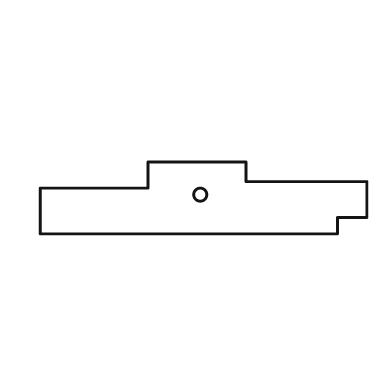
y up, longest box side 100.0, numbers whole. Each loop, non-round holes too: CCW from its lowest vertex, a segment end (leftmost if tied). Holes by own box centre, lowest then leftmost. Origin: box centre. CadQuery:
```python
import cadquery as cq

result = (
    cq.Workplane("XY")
    .moveTo(-50.0, -11.0)
    .lineTo(41.0, -11.0)
    .lineTo(41.0, -6.0)
    .lineTo(50.0, -6.0)
    .lineTo(50.0, 5.0)
    .lineTo(13.0, 5.0)
    .lineTo(13.0, 11.0)
    .lineTo(-17.0, 11.0)
    .lineTo(-17.0, 3.0)
    .lineTo(-50.0, 3.0)
    .close()
    .moveTo(-1.0, 1.0)
    .circle(2.0)
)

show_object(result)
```